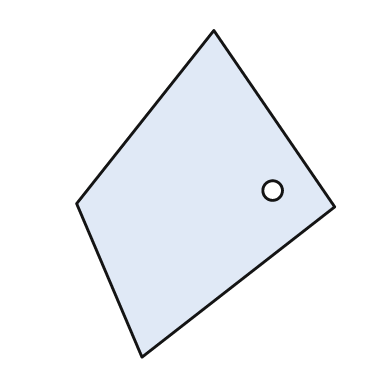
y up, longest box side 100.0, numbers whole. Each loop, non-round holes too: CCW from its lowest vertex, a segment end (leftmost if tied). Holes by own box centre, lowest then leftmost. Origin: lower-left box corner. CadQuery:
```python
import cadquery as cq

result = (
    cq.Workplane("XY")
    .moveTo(20.0, 0.0)
    .lineTo(79.0, 46.0)
    .lineTo(42.0, 100.0)
    .lineTo(0.0, 47.0)
    .close()
    .moveTo(60.0, 51.0)
    .circle(3.0)
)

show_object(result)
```